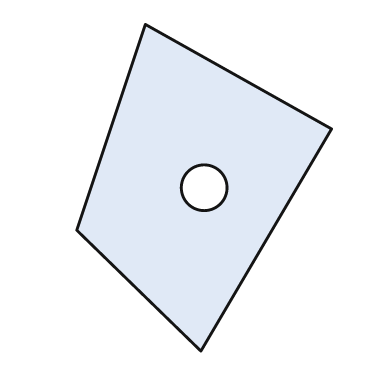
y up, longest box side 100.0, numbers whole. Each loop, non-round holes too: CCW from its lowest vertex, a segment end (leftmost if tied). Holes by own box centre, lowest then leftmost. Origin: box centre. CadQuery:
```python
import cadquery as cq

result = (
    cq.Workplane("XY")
    .moveTo(-1.0, -50.0)
    .lineTo(39.0, 18.0)
    .lineTo(-18.0, 50.0)
    .lineTo(-39.0, -13.0)
    .close()
    .moveTo(0.0, 0.0)
    .circle(7.0)
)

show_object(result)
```